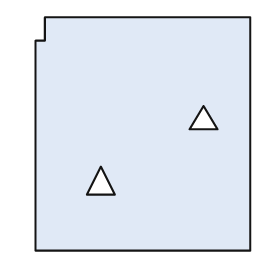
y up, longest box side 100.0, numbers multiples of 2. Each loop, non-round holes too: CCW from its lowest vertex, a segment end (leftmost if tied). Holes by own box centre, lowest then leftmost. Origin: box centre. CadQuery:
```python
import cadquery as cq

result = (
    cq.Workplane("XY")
    .moveTo(-46.0, -50.0)
    .lineTo(46.0, -50.0)
    .lineTo(46.0, 50.0)
    .lineTo(-42.0, 50.0)
    .lineTo(-42.0, 40.0)
    .lineTo(-46.0, 40.0)
    .close()
    .moveTo(-24.0, -26.0)
    .lineTo(-12.0, -26.0)
    .lineTo(-18.0, -14.0)
    .close()
    .moveTo(20.0, 2.0)
    .lineTo(32.0, 2.0)
    .lineTo(26.0, 12.0)
    .close()
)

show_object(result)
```